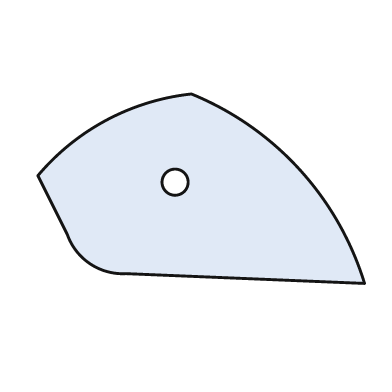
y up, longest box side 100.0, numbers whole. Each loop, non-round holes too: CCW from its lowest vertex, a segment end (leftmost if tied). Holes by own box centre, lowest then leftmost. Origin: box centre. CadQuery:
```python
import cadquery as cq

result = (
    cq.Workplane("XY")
    .moveTo(50.0, -29.0)
    .threePointArc((30.0, 6.0), (-3.0, 29.0))
    .threePointArc((-29.0, 21.0), (-50.0, 4.0))
    .lineTo(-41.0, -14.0)
    .threePointArc((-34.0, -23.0), (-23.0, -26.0))
    .close()
    .moveTo(-8.0, 2.0)
    .circle(4.0)
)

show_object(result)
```